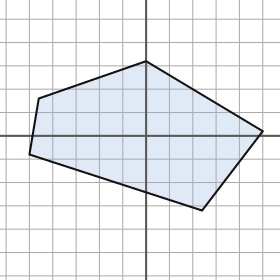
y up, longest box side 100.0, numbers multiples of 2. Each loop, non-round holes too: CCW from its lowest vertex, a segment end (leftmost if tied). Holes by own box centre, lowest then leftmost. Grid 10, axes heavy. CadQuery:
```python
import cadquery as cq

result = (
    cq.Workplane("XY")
    .moveTo(24.0, -32.0)
    .lineTo(50.0, 2.0)
    .lineTo(0.0, 32.0)
    .lineTo(-46.0, 16.0)
    .lineTo(-50.0, -8.0)
    .close()
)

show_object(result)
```